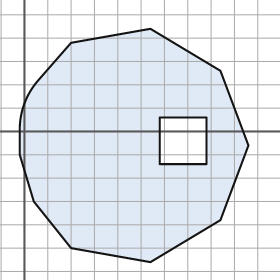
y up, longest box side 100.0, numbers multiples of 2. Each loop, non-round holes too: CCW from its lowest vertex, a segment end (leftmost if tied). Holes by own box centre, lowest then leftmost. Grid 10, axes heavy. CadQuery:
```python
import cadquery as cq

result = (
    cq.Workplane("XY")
    .moveTo(54.0, -56.0)
    .lineTo(84.0, -38.0)
    .lineTo(96.0, -6.0)
    .lineTo(84.0, 26.0)
    .lineTo(54.0, 44.0)
    .lineTo(20.0, 38.0)
    .lineTo(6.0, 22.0)
    .threePointArc((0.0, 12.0), (-2.0, 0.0))
    .lineTo(-2.0, -10.0)
    .lineTo(4.0, -30.0)
    .lineTo(20.0, -50.0)
    .close()
    .moveTo(58.0, -14.0)
    .lineTo(78.0, -14.0)
    .lineTo(78.0, 6.0)
    .lineTo(58.0, 6.0)
    .close()
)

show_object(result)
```